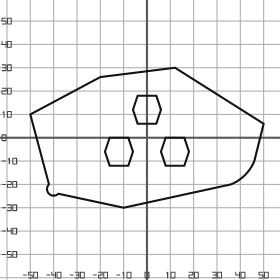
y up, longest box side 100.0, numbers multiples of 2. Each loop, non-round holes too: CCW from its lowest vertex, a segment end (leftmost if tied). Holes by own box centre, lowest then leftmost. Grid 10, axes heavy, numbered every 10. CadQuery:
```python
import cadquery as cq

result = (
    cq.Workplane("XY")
    .moveTo(-10.0, -30.0)
    .lineTo(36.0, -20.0)
    .threePointArc((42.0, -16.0), (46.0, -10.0))
    .lineTo(50.0, 6.0)
    .lineTo(12.0, 30.0)
    .lineTo(-20.0, 26.0)
    .lineTo(-50.0, 10.0)
    .lineTo(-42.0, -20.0)
    .threePointArc((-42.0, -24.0), (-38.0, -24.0))
    .close()
    .moveTo(-16.0, -12.0)
    .lineTo(-8.0, -12.0)
    .lineTo(-6.0, -6.0)
    .lineTo(-8.0, 0.0)
    .lineTo(-16.0, 0.0)
    .lineTo(-18.0, -6.0)
    .close()
    .moveTo(8.0, -12.0)
    .lineTo(16.0, -12.0)
    .lineTo(18.0, -6.0)
    .lineTo(16.0, 0.0)
    .lineTo(8.0, 0.0)
    .lineTo(6.0, -6.0)
    .close()
    .moveTo(-4.0, 6.0)
    .lineTo(4.0, 6.0)
    .lineTo(6.0, 12.0)
    .lineTo(4.0, 18.0)
    .lineTo(-4.0, 18.0)
    .lineTo(-6.0, 12.0)
    .close()
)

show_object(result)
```